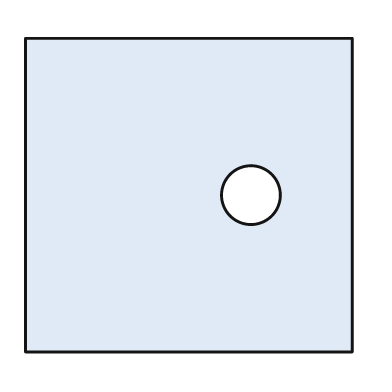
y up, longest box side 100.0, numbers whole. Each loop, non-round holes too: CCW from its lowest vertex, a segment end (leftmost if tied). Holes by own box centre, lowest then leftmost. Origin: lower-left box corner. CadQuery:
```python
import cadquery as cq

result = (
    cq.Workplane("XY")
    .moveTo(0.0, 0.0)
    .lineTo(100.0, 0.0)
    .lineTo(100.0, 96.0)
    .lineTo(0.0, 96.0)
    .close()
    .moveTo(69.0, 48.0)
    .circle(9.0)
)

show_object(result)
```